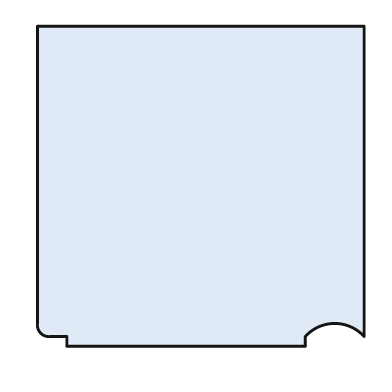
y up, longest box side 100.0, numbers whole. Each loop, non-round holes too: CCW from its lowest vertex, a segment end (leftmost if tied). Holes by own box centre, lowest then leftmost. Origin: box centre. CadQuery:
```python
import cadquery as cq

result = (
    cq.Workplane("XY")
    .moveTo(-41.0, -49.0)
    .lineTo(32.0, -49.0)
    .lineTo(32.0, -46.0)
    .threePointArc((41.0, -42.0), (50.0, -46.0))
    .lineTo(50.0, 49.0)
    .lineTo(-50.0, 49.0)
    .lineTo(-50.0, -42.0)
    .threePointArc((-49.0, -45.0), (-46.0, -46.0))
    .lineTo(-41.0, -46.0)
    .close()
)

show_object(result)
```